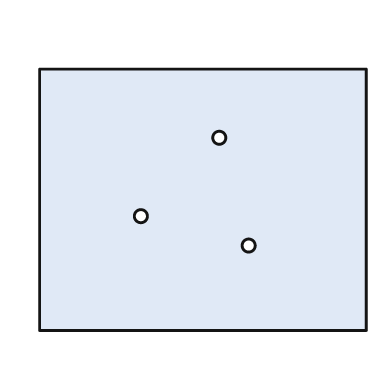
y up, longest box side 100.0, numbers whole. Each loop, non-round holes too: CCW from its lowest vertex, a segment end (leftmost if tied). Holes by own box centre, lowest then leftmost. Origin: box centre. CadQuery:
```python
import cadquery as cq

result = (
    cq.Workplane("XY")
    .moveTo(-50.0, -40.0)
    .lineTo(50.0, -40.0)
    .lineTo(50.0, 40.0)
    .lineTo(-50.0, 40.0)
    .close()
    .moveTo(14.0, -14.0)
    .circle(2.0)
    .moveTo(-19.0, -5.0)
    .circle(2.0)
    .moveTo(5.0, 19.0)
    .circle(2.0)
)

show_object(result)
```